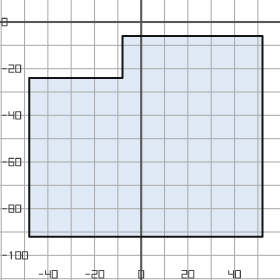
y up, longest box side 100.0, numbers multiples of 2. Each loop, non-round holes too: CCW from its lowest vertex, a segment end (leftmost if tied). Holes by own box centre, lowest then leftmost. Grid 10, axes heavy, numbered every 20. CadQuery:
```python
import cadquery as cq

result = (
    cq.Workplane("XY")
    .moveTo(-48.0, -92.0)
    .lineTo(52.0, -92.0)
    .lineTo(52.0, -6.0)
    .lineTo(-8.0, -6.0)
    .lineTo(-8.0, -24.0)
    .lineTo(-48.0, -24.0)
    .close()
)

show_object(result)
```